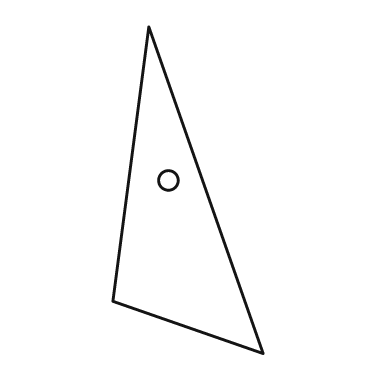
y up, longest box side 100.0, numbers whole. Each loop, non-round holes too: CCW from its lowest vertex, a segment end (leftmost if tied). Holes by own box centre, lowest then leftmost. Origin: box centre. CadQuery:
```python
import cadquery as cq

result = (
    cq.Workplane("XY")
    .moveTo(23.0, -50.0)
    .lineTo(-12.0, 50.0)
    .lineTo(-23.0, -34.0)
    .close()
    .moveTo(-6.0, 3.0)
    .circle(3.0)
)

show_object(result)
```